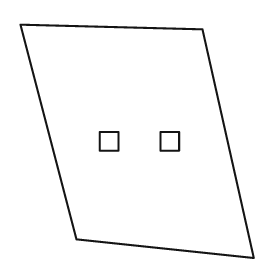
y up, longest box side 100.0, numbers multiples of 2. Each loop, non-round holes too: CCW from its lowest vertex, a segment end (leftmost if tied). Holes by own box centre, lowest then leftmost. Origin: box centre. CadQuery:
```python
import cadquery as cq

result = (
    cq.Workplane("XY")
    .moveTo(50.0, -50.0)
    .lineTo(28.0, 48.0)
    .lineTo(-50.0, 50.0)
    .lineTo(-26.0, -42.0)
    .close()
    .moveTo(-16.0, -4.0)
    .lineTo(-8.0, -4.0)
    .lineTo(-8.0, 4.0)
    .lineTo(-16.0, 4.0)
    .close()
    .moveTo(10.0, -4.0)
    .lineTo(18.0, -4.0)
    .lineTo(18.0, 4.0)
    .lineTo(10.0, 4.0)
    .close()
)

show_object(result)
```